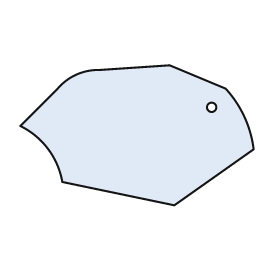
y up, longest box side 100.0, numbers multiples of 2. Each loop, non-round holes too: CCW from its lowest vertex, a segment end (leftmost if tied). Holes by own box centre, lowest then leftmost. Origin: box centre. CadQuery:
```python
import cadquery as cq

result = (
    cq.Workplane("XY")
    .moveTo(16.0, -30.0)
    .lineTo(50.0, -6.0)
    .threePointArc((46.0, 8.0), (38.0, 20.0))
    .lineTo(14.0, 30.0)
    .lineTo(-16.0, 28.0)
    .threePointArc((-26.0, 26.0), (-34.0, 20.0))
    .lineTo(-50.0, 4.0)
    .threePointArc((-38.0, -6.0), (-32.0, -20.0))
    .close()
    .moveTo(32.0, 12.0)
    .circle(2.0)
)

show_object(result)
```